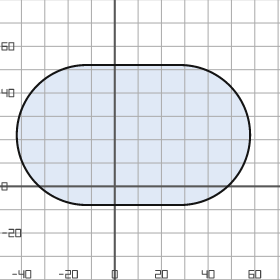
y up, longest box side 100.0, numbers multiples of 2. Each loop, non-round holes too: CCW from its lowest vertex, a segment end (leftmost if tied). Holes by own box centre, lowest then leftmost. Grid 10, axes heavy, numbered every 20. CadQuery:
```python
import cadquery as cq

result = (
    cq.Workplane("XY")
    .moveTo(-12.0, -8.0)
    .lineTo(28.0, -8.0)
    .threePointArc((58.0, 22.0), (28.0, 52.0))
    .lineTo(-12.0, 52.0)
    .threePointArc((-42.0, 22.0), (-12.0, -8.0))
    .close()
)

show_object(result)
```